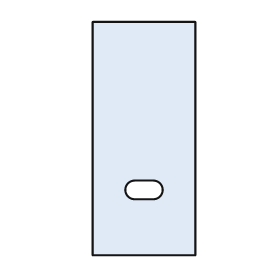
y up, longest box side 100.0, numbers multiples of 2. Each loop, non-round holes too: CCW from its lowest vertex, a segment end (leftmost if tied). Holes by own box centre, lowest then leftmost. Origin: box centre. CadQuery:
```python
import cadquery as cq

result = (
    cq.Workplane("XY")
    .moveTo(-22.0, -50.0)
    .lineTo(22.0, -50.0)
    .lineTo(22.0, 50.0)
    .lineTo(-22.0, 50.0)
    .close()
    .moveTo(-4.0, -26.0)
    .lineTo(4.0, -26.0)
    .threePointArc((8.0, -22.0), (4.0, -18.0))
    .lineTo(-4.0, -18.0)
    .threePointArc((-8.0, -22.0), (-4.0, -26.0))
    .close()
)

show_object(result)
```